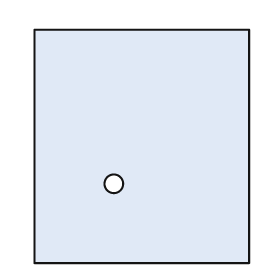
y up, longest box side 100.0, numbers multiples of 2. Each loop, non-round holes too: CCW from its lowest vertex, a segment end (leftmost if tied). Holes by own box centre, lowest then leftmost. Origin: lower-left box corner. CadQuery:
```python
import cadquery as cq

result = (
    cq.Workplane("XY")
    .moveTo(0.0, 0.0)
    .lineTo(92.0, 0.0)
    .lineTo(92.0, 100.0)
    .lineTo(0.0, 100.0)
    .close()
    .moveTo(34.0, 34.0)
    .circle(4.0)
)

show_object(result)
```